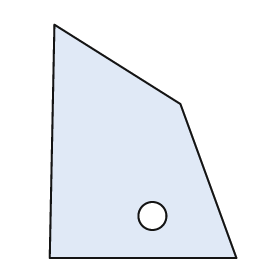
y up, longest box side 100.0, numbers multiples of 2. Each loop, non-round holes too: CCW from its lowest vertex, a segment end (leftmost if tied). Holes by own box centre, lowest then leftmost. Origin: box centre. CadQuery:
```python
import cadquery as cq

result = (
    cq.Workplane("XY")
    .moveTo(-40.0, -50.0)
    .lineTo(40.0, -50.0)
    .lineTo(16.0, 16.0)
    .lineTo(-38.0, 50.0)
    .close()
    .moveTo(4.0, -32.0)
    .circle(6.0)
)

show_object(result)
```